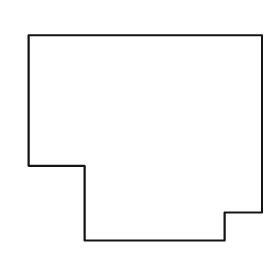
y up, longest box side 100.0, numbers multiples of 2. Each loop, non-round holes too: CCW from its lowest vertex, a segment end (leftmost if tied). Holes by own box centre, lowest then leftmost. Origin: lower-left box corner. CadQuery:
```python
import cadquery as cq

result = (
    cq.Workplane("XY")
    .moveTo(24.0, 0.0)
    .lineTo(84.0, 0.0)
    .lineTo(84.0, 12.0)
    .lineTo(100.0, 12.0)
    .lineTo(100.0, 88.0)
    .lineTo(0.0, 88.0)
    .lineTo(0.0, 32.0)
    .lineTo(24.0, 32.0)
    .close()
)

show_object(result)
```